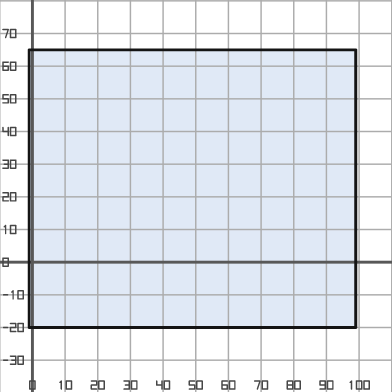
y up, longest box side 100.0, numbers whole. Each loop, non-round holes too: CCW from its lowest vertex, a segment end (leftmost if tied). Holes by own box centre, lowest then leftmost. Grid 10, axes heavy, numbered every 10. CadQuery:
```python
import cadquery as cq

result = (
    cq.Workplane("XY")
    .moveTo(-1.0, -20.0)
    .lineTo(99.0, -20.0)
    .lineTo(99.0, 65.0)
    .lineTo(-1.0, 65.0)
    .close()
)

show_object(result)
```